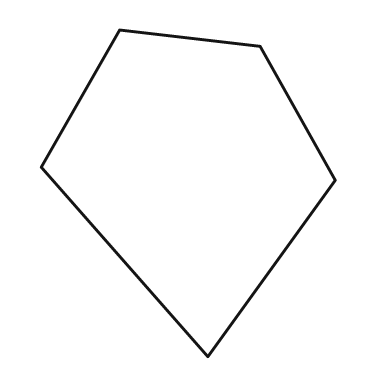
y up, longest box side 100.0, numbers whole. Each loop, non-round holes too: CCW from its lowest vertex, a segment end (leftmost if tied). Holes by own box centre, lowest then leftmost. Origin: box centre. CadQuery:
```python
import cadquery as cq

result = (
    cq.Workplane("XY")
    .moveTo(6.0, -50.0)
    .lineTo(45.0, 4.0)
    .lineTo(22.0, 45.0)
    .lineTo(-21.0, 50.0)
    .lineTo(-45.0, 8.0)
    .close()
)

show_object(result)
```